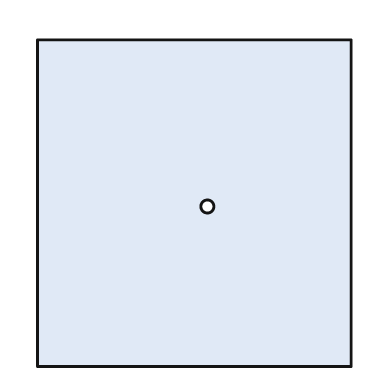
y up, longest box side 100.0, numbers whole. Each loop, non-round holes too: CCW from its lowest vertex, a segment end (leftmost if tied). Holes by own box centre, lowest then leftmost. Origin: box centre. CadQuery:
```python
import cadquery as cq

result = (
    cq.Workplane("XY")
    .moveTo(-48.0, -50.0)
    .lineTo(48.0, -50.0)
    .lineTo(48.0, 50.0)
    .lineTo(-48.0, 50.0)
    .close()
    .moveTo(4.0, -1.0)
    .circle(2.0)
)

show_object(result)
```